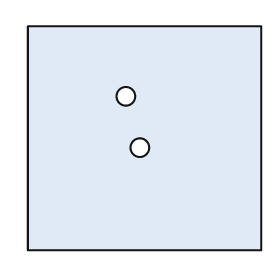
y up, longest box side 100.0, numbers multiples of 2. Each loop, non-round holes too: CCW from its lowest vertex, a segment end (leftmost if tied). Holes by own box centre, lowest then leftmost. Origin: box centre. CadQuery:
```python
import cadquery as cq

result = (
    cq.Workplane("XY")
    .moveTo(-50.0, -48.0)
    .lineTo(50.0, -48.0)
    .lineTo(50.0, 48.0)
    .lineTo(-50.0, 48.0)
    .close()
    .moveTo(-2.0, -4.0)
    .circle(4.0)
    .moveTo(-8.0, 18.0)
    .circle(4.0)
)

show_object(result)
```